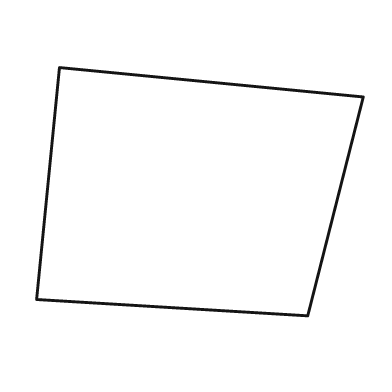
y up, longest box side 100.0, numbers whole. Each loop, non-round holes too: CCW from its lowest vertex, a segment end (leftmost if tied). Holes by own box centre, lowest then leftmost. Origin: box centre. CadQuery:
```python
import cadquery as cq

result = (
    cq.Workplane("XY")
    .moveTo(33.0, -38.0)
    .lineTo(50.0, 29.0)
    .lineTo(-43.0, 38.0)
    .lineTo(-50.0, -33.0)
    .close()
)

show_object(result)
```